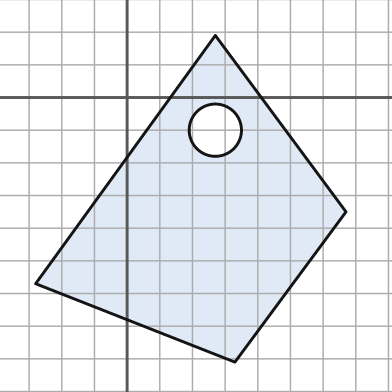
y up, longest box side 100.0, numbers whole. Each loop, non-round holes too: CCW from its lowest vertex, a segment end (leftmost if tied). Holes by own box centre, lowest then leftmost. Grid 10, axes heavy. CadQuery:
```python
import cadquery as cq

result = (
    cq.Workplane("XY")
    .moveTo(33.0, -81.0)
    .lineTo(67.0, -35.0)
    .lineTo(27.0, 19.0)
    .lineTo(-28.0, -57.0)
    .close()
    .moveTo(27.0, -10.0)
    .circle(8.0)
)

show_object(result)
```